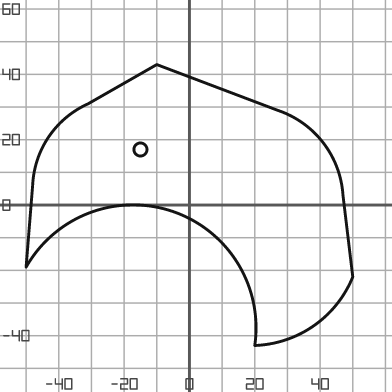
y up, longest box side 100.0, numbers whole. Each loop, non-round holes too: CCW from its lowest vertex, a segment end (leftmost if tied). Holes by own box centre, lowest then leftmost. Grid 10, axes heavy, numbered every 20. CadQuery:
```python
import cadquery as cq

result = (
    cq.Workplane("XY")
    .moveTo(20.0, -43.0)
    .threePointArc((38.0, -37.0), (50.0, -22.0))
    .lineTo(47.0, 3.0)
    .threePointArc((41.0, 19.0), (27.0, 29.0))
    .lineTo(-10.0, 43.0)
    .lineTo(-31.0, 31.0)
    .threePointArc((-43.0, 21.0), (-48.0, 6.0))
    .lineTo(-50.0, -19.0)
    .threePointArc((-5.0, -2.0), (20.0, -43.0))
    .close()
    .moveTo(-15.0, 17.0)
    .circle(2.0)
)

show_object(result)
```